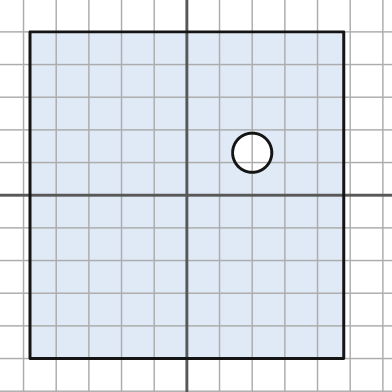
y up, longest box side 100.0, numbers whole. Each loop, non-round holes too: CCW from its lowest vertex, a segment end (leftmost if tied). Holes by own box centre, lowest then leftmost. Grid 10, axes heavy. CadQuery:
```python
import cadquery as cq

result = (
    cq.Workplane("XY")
    .moveTo(-48.0, -50.0)
    .lineTo(48.0, -50.0)
    .lineTo(48.0, 50.0)
    .lineTo(-48.0, 50.0)
    .close()
    .moveTo(20.0, 13.0)
    .circle(6.0)
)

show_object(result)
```